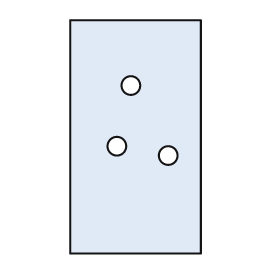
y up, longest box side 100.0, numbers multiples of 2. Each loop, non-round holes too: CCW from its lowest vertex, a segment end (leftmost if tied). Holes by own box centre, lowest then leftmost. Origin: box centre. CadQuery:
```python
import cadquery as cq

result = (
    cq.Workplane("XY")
    .moveTo(-28.0, -50.0)
    .lineTo(28.0, -50.0)
    .lineTo(28.0, 50.0)
    .lineTo(-28.0, 50.0)
    .close()
    .moveTo(14.0, -8.0)
    .circle(4.0)
    .moveTo(-8.0, -4.0)
    .circle(4.0)
    .moveTo(-2.0, 22.0)
    .circle(4.0)
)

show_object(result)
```